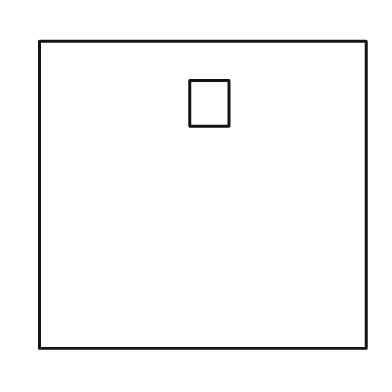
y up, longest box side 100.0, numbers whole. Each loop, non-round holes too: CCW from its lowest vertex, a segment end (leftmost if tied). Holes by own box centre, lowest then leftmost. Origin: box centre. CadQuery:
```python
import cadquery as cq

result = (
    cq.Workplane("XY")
    .moveTo(-50.0, -47.0)
    .lineTo(50.0, -47.0)
    .lineTo(50.0, 47.0)
    .lineTo(-50.0, 47.0)
    .close()
    .moveTo(-4.0, 21.0)
    .lineTo(8.0, 21.0)
    .lineTo(8.0, 35.0)
    .lineTo(-4.0, 35.0)
    .close()
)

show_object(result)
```